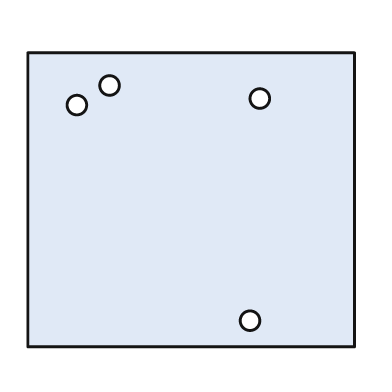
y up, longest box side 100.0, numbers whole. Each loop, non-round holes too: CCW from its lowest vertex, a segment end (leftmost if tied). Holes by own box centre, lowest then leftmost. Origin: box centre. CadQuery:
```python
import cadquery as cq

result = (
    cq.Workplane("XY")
    .moveTo(-50.0, -45.0)
    .lineTo(50.0, -45.0)
    .lineTo(50.0, 45.0)
    .lineTo(-50.0, 45.0)
    .close()
    .moveTo(18.0, -37.0)
    .circle(3.0)
    .moveTo(-35.0, 29.0)
    .circle(3.0)
    .moveTo(21.0, 31.0)
    .circle(3.0)
    .moveTo(-25.0, 35.0)
    .circle(3.0)
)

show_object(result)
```